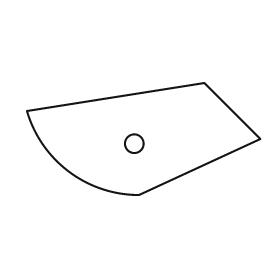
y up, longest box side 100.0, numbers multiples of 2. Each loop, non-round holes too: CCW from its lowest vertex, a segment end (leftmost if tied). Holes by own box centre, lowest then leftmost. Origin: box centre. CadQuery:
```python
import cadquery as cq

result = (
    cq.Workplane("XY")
    .moveTo(-2.0, -24.0)
    .lineTo(50.0, 0.0)
    .lineTo(26.0, 24.0)
    .lineTo(-50.0, 12.0)
    .threePointArc((-32.0, -14.0), (-2.0, -24.0))
    .close()
    .moveTo(-4.0, -2.0)
    .circle(4.0)
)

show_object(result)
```